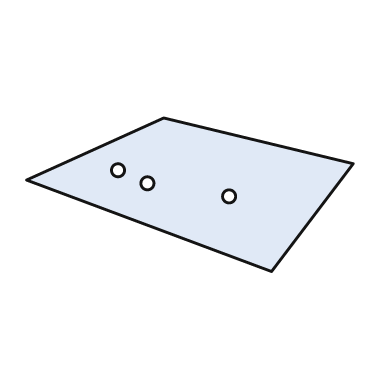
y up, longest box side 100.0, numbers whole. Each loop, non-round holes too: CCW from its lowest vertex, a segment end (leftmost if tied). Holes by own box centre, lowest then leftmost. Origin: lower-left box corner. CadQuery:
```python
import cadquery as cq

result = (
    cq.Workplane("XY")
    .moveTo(75.0, 0.0)
    .lineTo(100.0, 33.0)
    .lineTo(42.0, 47.0)
    .lineTo(0.0, 28.0)
    .close()
    .moveTo(62.0, 23.0)
    .circle(2.0)
    .moveTo(37.0, 27.0)
    .circle(2.0)
    .moveTo(28.0, 31.0)
    .circle(2.0)
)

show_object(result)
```